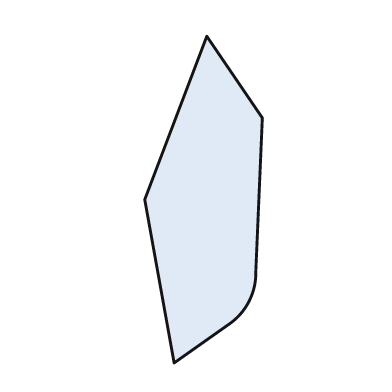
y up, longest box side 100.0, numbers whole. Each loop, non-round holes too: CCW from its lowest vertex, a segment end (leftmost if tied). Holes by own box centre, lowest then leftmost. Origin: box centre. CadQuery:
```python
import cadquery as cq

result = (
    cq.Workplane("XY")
    .moveTo(-9.0, -50.0)
    .lineTo(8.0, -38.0)
    .threePointArc((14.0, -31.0), (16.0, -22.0))
    .lineTo(18.0, 25.0)
    .lineTo(1.0, 50.0)
    .lineTo(-18.0, 0.0)
    .close()
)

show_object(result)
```